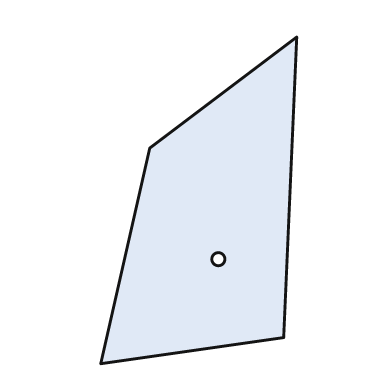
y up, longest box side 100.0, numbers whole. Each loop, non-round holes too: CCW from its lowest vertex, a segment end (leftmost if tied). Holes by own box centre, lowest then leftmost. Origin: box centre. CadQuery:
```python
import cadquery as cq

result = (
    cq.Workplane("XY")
    .moveTo(-30.0, -50.0)
    .lineTo(26.0, -42.0)
    .lineTo(30.0, 50.0)
    .lineTo(-15.0, 16.0)
    .close()
    .moveTo(6.0, -18.0)
    .circle(2.0)
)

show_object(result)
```